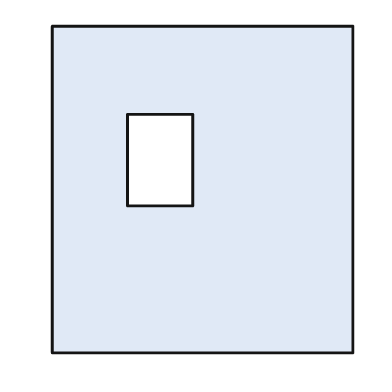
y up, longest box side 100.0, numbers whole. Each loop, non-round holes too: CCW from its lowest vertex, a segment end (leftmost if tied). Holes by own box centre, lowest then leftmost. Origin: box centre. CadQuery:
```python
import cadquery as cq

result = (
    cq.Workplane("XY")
    .moveTo(-46.0, -50.0)
    .lineTo(46.0, -50.0)
    .lineTo(46.0, 50.0)
    .lineTo(-46.0, 50.0)
    .close()
    .moveTo(-23.0, -5.0)
    .lineTo(-3.0, -5.0)
    .lineTo(-3.0, 23.0)
    .lineTo(-23.0, 23.0)
    .close()
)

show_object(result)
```